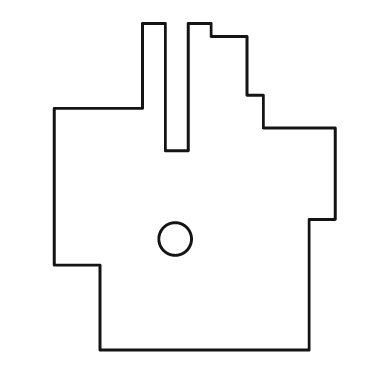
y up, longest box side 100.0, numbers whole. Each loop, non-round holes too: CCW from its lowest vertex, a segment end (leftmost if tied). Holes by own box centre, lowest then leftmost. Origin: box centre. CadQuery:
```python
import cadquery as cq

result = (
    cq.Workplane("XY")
    .moveTo(-29.0, -50.0)
    .lineTo(35.0, -50.0)
    .lineTo(35.0, -10.0)
    .lineTo(43.0, -10.0)
    .lineTo(43.0, 18.0)
    .lineTo(21.0, 18.0)
    .lineTo(21.0, 28.0)
    .lineTo(16.0, 28.0)
    .lineTo(16.0, 46.0)
    .lineTo(5.0, 46.0)
    .lineTo(5.0, 50.0)
    .lineTo(-2.0, 50.0)
    .lineTo(-2.0, 11.0)
    .lineTo(-9.0, 11.0)
    .lineTo(-9.0, 50.0)
    .lineTo(-16.0, 50.0)
    .lineTo(-16.0, 24.0)
    .lineTo(-43.0, 24.0)
    .lineTo(-43.0, -24.0)
    .lineTo(-29.0, -24.0)
    .close()
    .moveTo(-6.0, -16.0)
    .circle(5.0)
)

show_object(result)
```